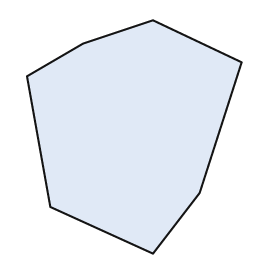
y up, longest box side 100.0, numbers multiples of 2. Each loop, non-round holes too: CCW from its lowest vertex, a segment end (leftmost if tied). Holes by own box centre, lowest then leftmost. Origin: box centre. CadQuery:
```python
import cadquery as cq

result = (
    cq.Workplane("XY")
    .moveTo(8.0, -50.0)
    .lineTo(28.0, -24.0)
    .lineTo(46.0, 32.0)
    .lineTo(8.0, 50.0)
    .lineTo(-22.0, 40.0)
    .lineTo(-46.0, 26.0)
    .lineTo(-36.0, -30.0)
    .close()
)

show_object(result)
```